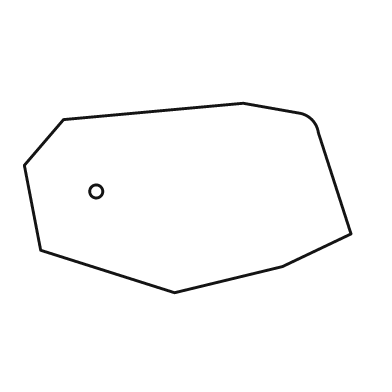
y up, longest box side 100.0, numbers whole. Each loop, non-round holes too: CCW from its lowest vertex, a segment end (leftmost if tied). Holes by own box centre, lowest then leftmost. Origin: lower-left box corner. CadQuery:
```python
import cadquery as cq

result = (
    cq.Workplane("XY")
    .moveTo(46.0, 0.0)
    .lineTo(79.0, 8.0)
    .lineTo(100.0, 18.0)
    .lineTo(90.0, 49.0)
    .threePointArc((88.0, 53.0), (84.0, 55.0))
    .lineTo(67.0, 58.0)
    .lineTo(12.0, 53.0)
    .lineTo(0.0, 39.0)
    .lineTo(5.0, 13.0)
    .close()
    .moveTo(22.0, 31.0)
    .circle(2.0)
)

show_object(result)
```